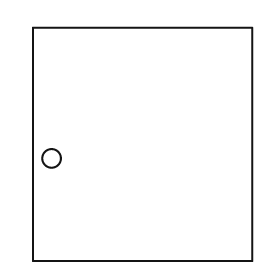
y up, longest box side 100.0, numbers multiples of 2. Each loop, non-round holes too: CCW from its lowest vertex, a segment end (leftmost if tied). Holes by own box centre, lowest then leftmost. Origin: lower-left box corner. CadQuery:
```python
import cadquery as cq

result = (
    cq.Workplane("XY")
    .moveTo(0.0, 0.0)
    .lineTo(94.0, 0.0)
    .lineTo(94.0, 100.0)
    .lineTo(0.0, 100.0)
    .close()
    .moveTo(8.0, 44.0)
    .circle(4.0)
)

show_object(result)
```